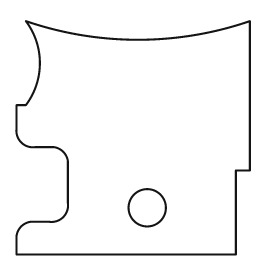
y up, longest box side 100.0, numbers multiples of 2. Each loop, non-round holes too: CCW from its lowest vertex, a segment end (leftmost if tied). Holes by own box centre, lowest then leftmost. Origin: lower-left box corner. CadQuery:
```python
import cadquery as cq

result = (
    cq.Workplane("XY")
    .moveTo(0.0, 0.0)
    .lineTo(94.0, 0.0)
    .lineTo(94.0, 36.0)
    .lineTo(100.0, 36.0)
    .lineTo(100.0, 100.0)
    .threePointArc((52.0, 92.0), (4.0, 100.0))
    .threePointArc((10.0, 82.0), (4.0, 64.0))
    .lineTo(0.0, 64.0)
    .lineTo(0.0, 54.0)
    .threePointArc((2.0, 48.0), (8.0, 46.0))
    .lineTo(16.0, 46.0)
    .threePointArc((20.0, 44.0), (22.0, 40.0))
    .lineTo(22.0, 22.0)
    .threePointArc((20.0, 16.0), (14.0, 14.0))
    .lineTo(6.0, 14.0)
    .threePointArc((2.0, 12.0), (0.0, 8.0))
    .close()
    .moveTo(56.0, 20.0)
    .circle(8.0)
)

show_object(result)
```